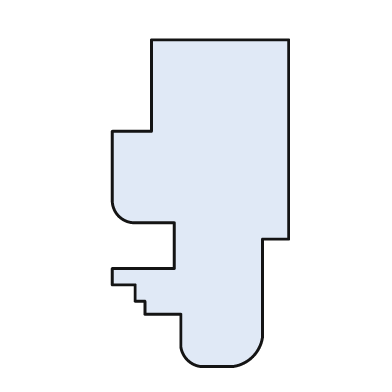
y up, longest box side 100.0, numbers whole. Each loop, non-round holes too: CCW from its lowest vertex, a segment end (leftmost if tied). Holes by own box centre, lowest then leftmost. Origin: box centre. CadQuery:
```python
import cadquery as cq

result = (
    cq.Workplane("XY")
    .moveTo(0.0, -50.0)
    .lineTo(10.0, -50.0)
    .threePointArc((16.0, -47.0), (19.0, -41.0))
    .lineTo(19.0, -11.0)
    .lineTo(27.0, -11.0)
    .lineTo(27.0, 50.0)
    .lineTo(-15.0, 50.0)
    .lineTo(-15.0, 22.0)
    .lineTo(-27.0, 22.0)
    .lineTo(-27.0, 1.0)
    .threePointArc((-25.0, -4.0), (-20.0, -6.0))
    .lineTo(-8.0, -6.0)
    .lineTo(-8.0, -20.0)
    .lineTo(-27.0, -20.0)
    .lineTo(-27.0, -25.0)
    .lineTo(-20.0, -25.0)
    .lineTo(-20.0, -30.0)
    .lineTo(-17.0, -30.0)
    .lineTo(-17.0, -34.0)
    .lineTo(-6.0, -34.0)
    .lineTo(-6.0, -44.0)
    .threePointArc((-4.0, -48.0), (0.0, -50.0))
    .close()
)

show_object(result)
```